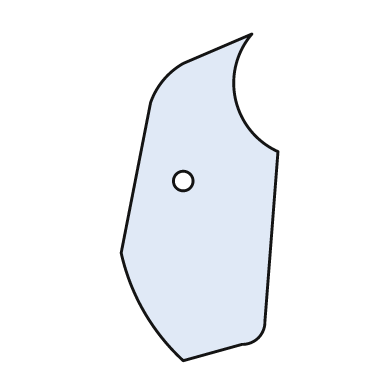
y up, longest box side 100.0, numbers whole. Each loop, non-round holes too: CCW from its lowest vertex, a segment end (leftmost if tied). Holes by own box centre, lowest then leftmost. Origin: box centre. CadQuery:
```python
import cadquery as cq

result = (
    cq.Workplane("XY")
    .moveTo(-5.0, -50.0)
    .lineTo(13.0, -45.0)
    .threePointArc((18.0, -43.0), (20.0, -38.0))
    .lineTo(24.0, 14.0)
    .threePointArc((11.0, 30.0), (16.0, 50.0))
    .lineTo(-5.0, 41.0)
    .threePointArc((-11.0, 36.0), (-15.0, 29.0))
    .lineTo(-24.0, -17.0)
    .threePointArc((-17.0, -35.0), (-5.0, -50.0))
    .close()
    .moveTo(-5.0, 5.0)
    .circle(3.0)
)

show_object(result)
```